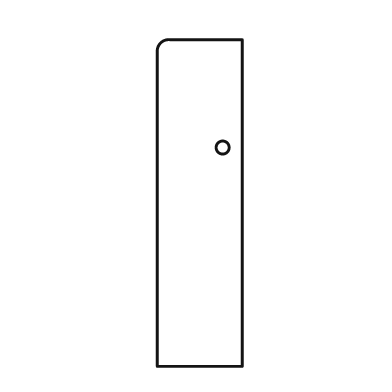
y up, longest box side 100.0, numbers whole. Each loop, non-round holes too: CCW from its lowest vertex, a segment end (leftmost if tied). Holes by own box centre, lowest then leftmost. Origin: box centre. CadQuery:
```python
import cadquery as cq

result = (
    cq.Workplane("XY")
    .moveTo(-13.0, -50.0)
    .lineTo(13.0, -50.0)
    .lineTo(13.0, 50.0)
    .lineTo(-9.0, 50.0)
    .threePointArc((-12.0, 49.0), (-13.0, 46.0))
    .close()
    .moveTo(7.0, 17.0)
    .circle(2.0)
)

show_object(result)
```